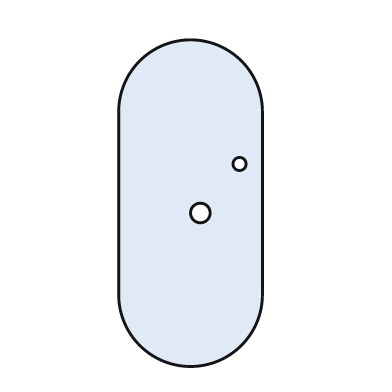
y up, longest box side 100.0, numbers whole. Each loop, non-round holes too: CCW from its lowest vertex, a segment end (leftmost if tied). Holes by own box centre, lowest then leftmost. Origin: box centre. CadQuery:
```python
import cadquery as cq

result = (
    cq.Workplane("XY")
    .moveTo(-22.0, -28.0)
    .threePointArc((0.0, -50.0), (22.0, -28.0))
    .lineTo(22.0, 28.0)
    .threePointArc((0.0, 50.0), (-22.0, 28.0))
    .close()
    .moveTo(3.0, -3.0)
    .circle(3.0)
    .moveTo(15.0, 12.0)
    .circle(2.0)
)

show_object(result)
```